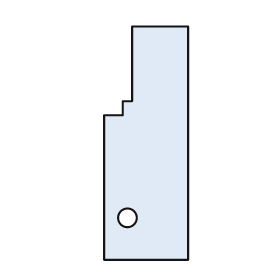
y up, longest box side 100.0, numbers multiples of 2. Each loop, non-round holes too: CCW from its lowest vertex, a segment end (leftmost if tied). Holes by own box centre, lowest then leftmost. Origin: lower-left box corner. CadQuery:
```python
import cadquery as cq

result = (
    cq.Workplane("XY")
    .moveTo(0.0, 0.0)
    .lineTo(36.0, 0.0)
    .lineTo(36.0, 100.0)
    .lineTo(12.0, 100.0)
    .lineTo(12.0, 68.0)
    .lineTo(8.0, 68.0)
    .lineTo(8.0, 62.0)
    .lineTo(0.0, 62.0)
    .close()
    .moveTo(10.0, 18.0)
    .circle(4.0)
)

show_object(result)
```